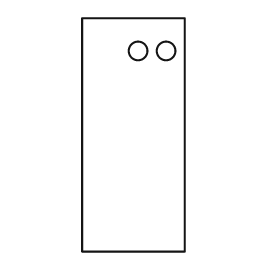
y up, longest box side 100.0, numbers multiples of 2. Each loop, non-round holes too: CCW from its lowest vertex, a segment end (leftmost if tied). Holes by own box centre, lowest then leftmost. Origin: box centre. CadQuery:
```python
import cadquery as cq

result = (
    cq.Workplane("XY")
    .moveTo(-22.0, -50.0)
    .lineTo(22.0, -50.0)
    .lineTo(22.0, 50.0)
    .lineTo(-22.0, 50.0)
    .close()
    .moveTo(2.0, 36.0)
    .circle(4.0)
    .moveTo(14.0, 36.0)
    .circle(4.0)
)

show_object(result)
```